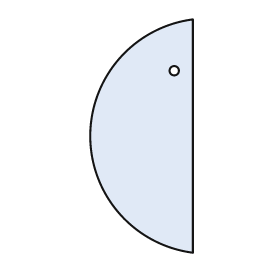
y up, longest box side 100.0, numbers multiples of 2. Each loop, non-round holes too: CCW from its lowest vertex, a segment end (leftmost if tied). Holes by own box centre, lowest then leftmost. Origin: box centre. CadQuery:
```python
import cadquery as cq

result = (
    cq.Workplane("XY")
    .moveTo(22.0, -50.0)
    .lineTo(22.0, 50.0)
    .threePointArc((-22.0, 0.0), (22.0, -50.0))
    .close()
    .moveTo(14.0, 28.0)
    .circle(2.0)
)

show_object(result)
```